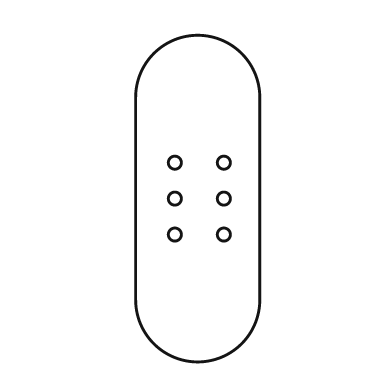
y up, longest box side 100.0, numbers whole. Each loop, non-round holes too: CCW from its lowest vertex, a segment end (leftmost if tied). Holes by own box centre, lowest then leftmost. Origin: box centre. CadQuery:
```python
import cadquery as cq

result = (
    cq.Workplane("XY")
    .moveTo(-19.0, -31.0)
    .threePointArc((0.0, -50.0), (19.0, -31.0))
    .lineTo(19.0, 31.0)
    .threePointArc((0.0, 50.0), (-19.0, 31.0))
    .close()
    .moveTo(-7.0, -11.0)
    .circle(2.0)
    .moveTo(8.0, -11.0)
    .circle(2.0)
    .moveTo(-7.0, 0.0)
    .circle(2.0)
    .moveTo(8.0, 0.0)
    .circle(2.0)
    .moveTo(-7.0, 11.0)
    .circle(2.0)
    .moveTo(8.0, 11.0)
    .circle(2.0)
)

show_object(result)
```